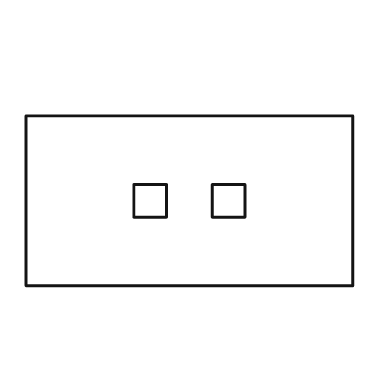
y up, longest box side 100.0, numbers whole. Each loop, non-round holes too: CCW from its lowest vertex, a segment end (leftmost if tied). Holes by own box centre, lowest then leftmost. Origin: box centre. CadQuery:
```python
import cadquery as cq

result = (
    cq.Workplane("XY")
    .moveTo(-50.0, -26.0)
    .lineTo(50.0, -26.0)
    .lineTo(50.0, 26.0)
    .lineTo(-50.0, 26.0)
    .close()
    .moveTo(-17.0, -5.0)
    .lineTo(-7.0, -5.0)
    .lineTo(-7.0, 5.0)
    .lineTo(-17.0, 5.0)
    .close()
    .moveTo(7.0, -5.0)
    .lineTo(17.0, -5.0)
    .lineTo(17.0, 5.0)
    .lineTo(7.0, 5.0)
    .close()
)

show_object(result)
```